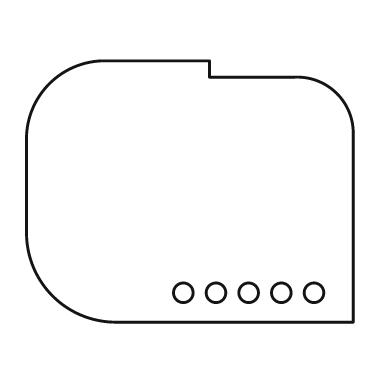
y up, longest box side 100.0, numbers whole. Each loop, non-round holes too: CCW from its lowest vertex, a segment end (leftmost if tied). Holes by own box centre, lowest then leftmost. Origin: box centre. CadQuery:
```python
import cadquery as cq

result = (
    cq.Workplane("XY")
    .moveTo(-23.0, -40.0)
    .lineTo(50.0, -40.0)
    .lineTo(50.0, 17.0)
    .threePointArc((45.0, 30.0), (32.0, 35.0))
    .lineTo(6.0, 35.0)
    .lineTo(6.0, 40.0)
    .lineTo(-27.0, 40.0)
    .threePointArc((-43.0, 33.0), (-50.0, 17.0))
    .lineTo(-50.0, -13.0)
    .threePointArc((-42.0, -32.0), (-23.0, -40.0))
    .close()
    .moveTo(-2.0, -31.0)
    .circle(3.0)
    .moveTo(8.0, -31.0)
    .circle(3.0)
    .moveTo(18.0, -31.0)
    .circle(3.0)
    .moveTo(28.0, -31.0)
    .circle(3.0)
    .moveTo(38.0, -31.0)
    .circle(3.0)
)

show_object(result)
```